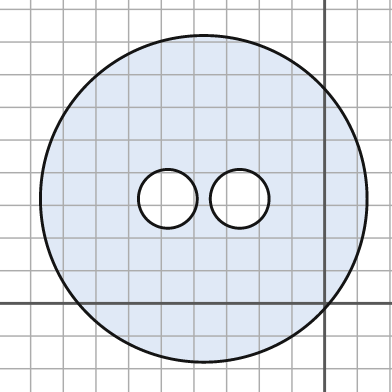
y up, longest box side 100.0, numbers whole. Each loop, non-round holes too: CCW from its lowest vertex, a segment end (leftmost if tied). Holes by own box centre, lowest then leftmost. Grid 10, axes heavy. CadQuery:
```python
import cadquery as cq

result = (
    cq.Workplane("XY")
    .moveTo(-37.0, 32.0)
    .circle(50.0)
    .moveTo(-48.0, 32.0)
    .circle(9.0)
    .moveTo(-26.0, 32.0)
    .circle(9.0)
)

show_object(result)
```